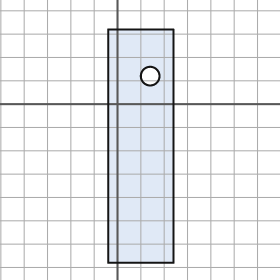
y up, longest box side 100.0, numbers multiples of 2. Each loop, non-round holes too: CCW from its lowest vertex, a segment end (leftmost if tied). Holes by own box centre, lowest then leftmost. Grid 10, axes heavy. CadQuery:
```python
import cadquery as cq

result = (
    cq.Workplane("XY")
    .moveTo(-4.0, -68.0)
    .lineTo(24.0, -68.0)
    .lineTo(24.0, 32.0)
    .lineTo(-4.0, 32.0)
    .close()
    .moveTo(14.0, 12.0)
    .circle(4.0)
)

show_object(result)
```